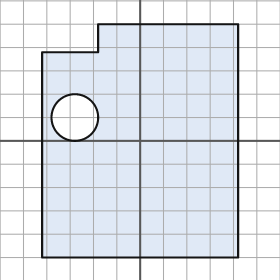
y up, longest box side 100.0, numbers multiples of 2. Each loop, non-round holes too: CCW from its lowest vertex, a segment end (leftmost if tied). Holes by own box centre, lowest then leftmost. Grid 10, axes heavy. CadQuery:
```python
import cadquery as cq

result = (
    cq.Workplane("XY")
    .moveTo(-42.0, -50.0)
    .lineTo(42.0, -50.0)
    .lineTo(42.0, 50.0)
    .lineTo(-18.0, 50.0)
    .lineTo(-18.0, 38.0)
    .lineTo(-42.0, 38.0)
    .close()
    .moveTo(-28.0, 10.0)
    .circle(10.0)
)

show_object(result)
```